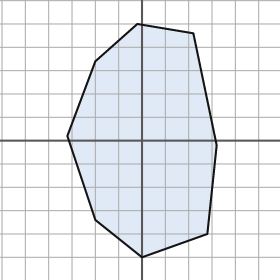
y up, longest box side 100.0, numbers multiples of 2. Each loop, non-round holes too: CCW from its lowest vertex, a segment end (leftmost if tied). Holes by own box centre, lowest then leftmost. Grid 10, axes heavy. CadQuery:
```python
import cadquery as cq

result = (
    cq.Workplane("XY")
    .moveTo(0.0, -50.0)
    .lineTo(28.0, -40.0)
    .lineTo(32.0, -2.0)
    .lineTo(22.0, 46.0)
    .lineTo(-2.0, 50.0)
    .lineTo(-20.0, 34.0)
    .lineTo(-32.0, 2.0)
    .lineTo(-20.0, -34.0)
    .close()
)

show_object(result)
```